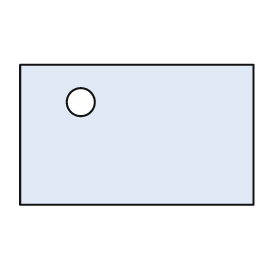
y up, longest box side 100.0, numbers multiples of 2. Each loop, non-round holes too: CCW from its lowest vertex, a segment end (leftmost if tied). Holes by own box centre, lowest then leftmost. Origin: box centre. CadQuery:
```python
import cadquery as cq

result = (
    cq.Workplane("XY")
    .moveTo(-50.0, -30.0)
    .lineTo(50.0, -30.0)
    .lineTo(50.0, 30.0)
    .lineTo(-50.0, 30.0)
    .close()
    .moveTo(-24.0, 14.0)
    .circle(6.0)
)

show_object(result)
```